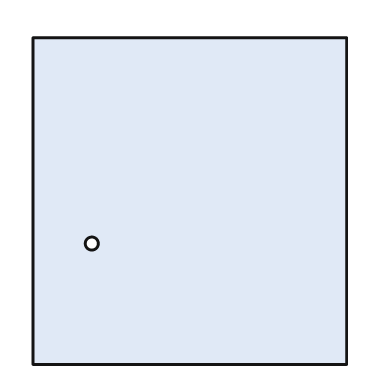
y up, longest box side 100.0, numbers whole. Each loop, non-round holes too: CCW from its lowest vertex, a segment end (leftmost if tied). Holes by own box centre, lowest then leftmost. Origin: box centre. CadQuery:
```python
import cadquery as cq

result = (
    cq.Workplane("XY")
    .moveTo(-48.0, -50.0)
    .lineTo(48.0, -50.0)
    .lineTo(48.0, 50.0)
    .lineTo(-48.0, 50.0)
    .close()
    .moveTo(-30.0, -13.0)
    .circle(2.0)
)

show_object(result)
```